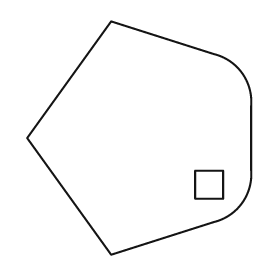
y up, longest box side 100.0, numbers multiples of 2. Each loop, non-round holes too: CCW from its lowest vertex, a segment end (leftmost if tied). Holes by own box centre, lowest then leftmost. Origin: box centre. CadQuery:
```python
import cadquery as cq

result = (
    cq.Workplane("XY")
    .moveTo(-12.0, -50.0)
    .lineTo(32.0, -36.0)
    .threePointArc((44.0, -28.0), (48.0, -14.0))
    .lineTo(48.0, 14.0)
    .threePointArc((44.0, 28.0), (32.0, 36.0))
    .lineTo(-12.0, 50.0)
    .lineTo(-48.0, 0.0)
    .close()
    .moveTo(24.0, -26.0)
    .lineTo(36.0, -26.0)
    .lineTo(36.0, -14.0)
    .lineTo(24.0, -14.0)
    .close()
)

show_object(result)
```